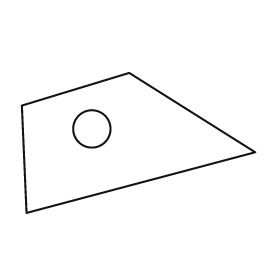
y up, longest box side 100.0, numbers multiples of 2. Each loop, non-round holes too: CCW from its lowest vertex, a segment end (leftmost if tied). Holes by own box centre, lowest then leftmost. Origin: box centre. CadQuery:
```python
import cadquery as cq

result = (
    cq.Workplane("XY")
    .moveTo(-48.0, -30.0)
    .lineTo(50.0, -4.0)
    .lineTo(-4.0, 30.0)
    .lineTo(-50.0, 16.0)
    .close()
    .moveTo(-20.0, 6.0)
    .circle(8.0)
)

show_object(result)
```